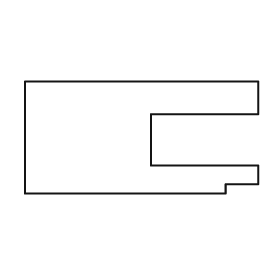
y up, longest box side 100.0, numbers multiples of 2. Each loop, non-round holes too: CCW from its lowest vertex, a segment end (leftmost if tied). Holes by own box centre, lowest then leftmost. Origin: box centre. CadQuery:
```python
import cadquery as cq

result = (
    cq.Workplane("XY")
    .moveTo(-50.0, -24.0)
    .lineTo(36.0, -24.0)
    .lineTo(36.0, -20.0)
    .lineTo(50.0, -20.0)
    .lineTo(50.0, -12.0)
    .lineTo(4.0, -12.0)
    .lineTo(4.0, 10.0)
    .lineTo(50.0, 10.0)
    .lineTo(50.0, 24.0)
    .lineTo(-50.0, 24.0)
    .close()
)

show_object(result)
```